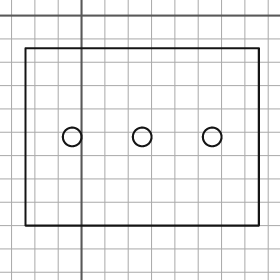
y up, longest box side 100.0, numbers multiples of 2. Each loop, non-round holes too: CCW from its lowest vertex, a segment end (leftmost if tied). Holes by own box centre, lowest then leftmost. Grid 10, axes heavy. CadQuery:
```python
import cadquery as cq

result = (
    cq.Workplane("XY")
    .moveTo(-24.0, -90.0)
    .lineTo(76.0, -90.0)
    .lineTo(76.0, -14.0)
    .lineTo(-24.0, -14.0)
    .close()
    .moveTo(-4.0, -52.0)
    .circle(4.0)
    .moveTo(26.0, -52.0)
    .circle(4.0)
    .moveTo(56.0, -52.0)
    .circle(4.0)
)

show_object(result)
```